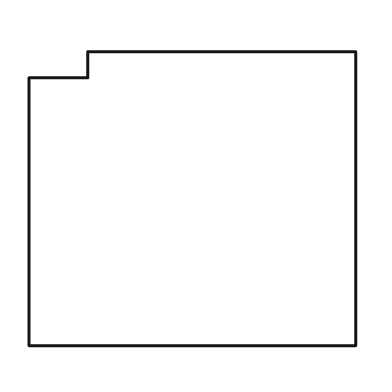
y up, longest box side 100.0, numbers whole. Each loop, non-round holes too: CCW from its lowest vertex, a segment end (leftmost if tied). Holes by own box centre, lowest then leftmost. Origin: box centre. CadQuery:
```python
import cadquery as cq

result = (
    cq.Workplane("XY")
    .moveTo(-50.0, -45.0)
    .lineTo(50.0, -45.0)
    .lineTo(50.0, 45.0)
    .lineTo(-32.0, 45.0)
    .lineTo(-32.0, 37.0)
    .lineTo(-50.0, 37.0)
    .close()
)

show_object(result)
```